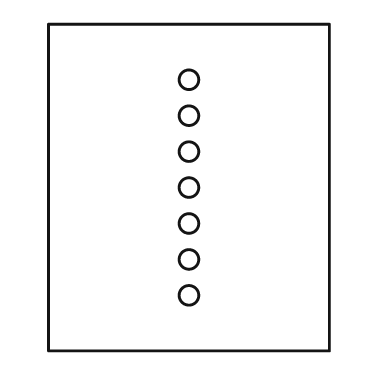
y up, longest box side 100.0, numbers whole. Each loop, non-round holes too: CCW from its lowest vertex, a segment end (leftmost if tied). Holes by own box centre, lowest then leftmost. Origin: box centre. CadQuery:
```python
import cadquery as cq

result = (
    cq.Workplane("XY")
    .moveTo(-43.0, -50.0)
    .lineTo(43.0, -50.0)
    .lineTo(43.0, 50.0)
    .lineTo(-43.0, 50.0)
    .close()
    .moveTo(0.0, -33.0)
    .circle(3.0)
    .moveTo(0.0, -22.0)
    .circle(3.0)
    .moveTo(0.0, -11.0)
    .circle(3.0)
    .moveTo(0.0, 0.0)
    .circle(3.0)
    .moveTo(0.0, 11.0)
    .circle(3.0)
    .moveTo(0.0, 22.0)
    .circle(3.0)
    .moveTo(0.0, 33.0)
    .circle(3.0)
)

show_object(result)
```